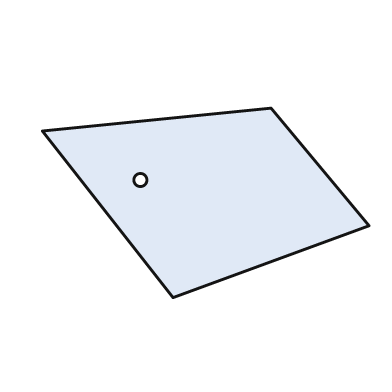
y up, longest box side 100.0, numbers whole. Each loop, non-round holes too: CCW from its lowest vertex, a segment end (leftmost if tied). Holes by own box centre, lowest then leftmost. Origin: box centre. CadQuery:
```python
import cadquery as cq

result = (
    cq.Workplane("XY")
    .moveTo(-10.0, -29.0)
    .lineTo(50.0, -7.0)
    .lineTo(20.0, 29.0)
    .lineTo(-50.0, 22.0)
    .close()
    .moveTo(-20.0, 7.0)
    .circle(2.0)
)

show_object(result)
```